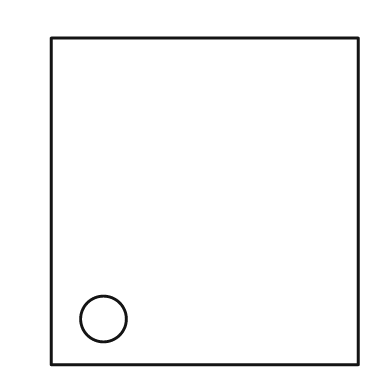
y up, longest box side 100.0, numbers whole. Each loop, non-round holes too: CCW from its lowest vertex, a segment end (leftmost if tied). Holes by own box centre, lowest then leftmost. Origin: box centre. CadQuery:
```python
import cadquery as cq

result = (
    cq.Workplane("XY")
    .moveTo(-47.0, -50.0)
    .lineTo(47.0, -50.0)
    .lineTo(47.0, 50.0)
    .lineTo(-47.0, 50.0)
    .close()
    .moveTo(-31.0, -36.0)
    .circle(7.0)
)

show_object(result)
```